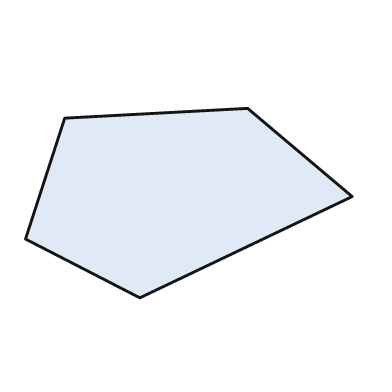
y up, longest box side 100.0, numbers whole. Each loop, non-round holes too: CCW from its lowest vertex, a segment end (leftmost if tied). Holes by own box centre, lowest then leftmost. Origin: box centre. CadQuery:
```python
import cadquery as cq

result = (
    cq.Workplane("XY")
    .moveTo(-15.0, -29.0)
    .lineTo(50.0, 2.0)
    .lineTo(18.0, 29.0)
    .lineTo(-38.0, 26.0)
    .lineTo(-50.0, -11.0)
    .close()
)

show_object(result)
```